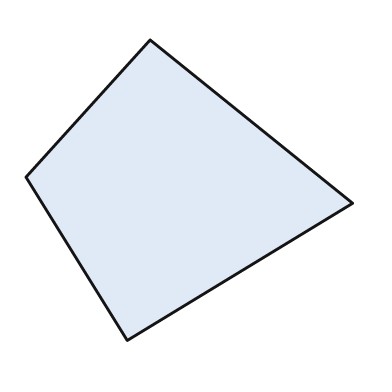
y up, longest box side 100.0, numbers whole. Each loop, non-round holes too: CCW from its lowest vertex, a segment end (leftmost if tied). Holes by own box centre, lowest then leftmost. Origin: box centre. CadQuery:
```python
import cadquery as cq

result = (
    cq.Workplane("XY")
    .moveTo(-19.0, -46.0)
    .lineTo(50.0, -4.0)
    .lineTo(-12.0, 46.0)
    .lineTo(-50.0, 4.0)
    .close()
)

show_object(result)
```